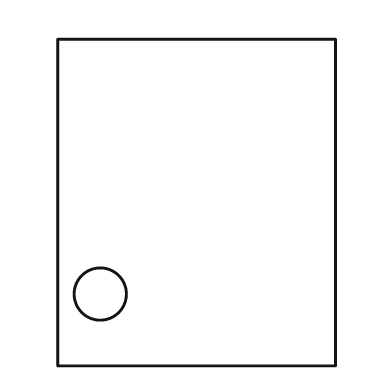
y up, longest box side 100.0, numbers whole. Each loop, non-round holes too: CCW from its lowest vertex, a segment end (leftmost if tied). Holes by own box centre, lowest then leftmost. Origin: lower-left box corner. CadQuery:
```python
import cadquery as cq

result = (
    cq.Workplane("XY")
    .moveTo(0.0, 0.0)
    .lineTo(85.0, 0.0)
    .lineTo(85.0, 100.0)
    .lineTo(0.0, 100.0)
    .close()
    .moveTo(13.0, 22.0)
    .circle(8.0)
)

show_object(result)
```